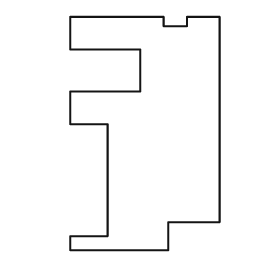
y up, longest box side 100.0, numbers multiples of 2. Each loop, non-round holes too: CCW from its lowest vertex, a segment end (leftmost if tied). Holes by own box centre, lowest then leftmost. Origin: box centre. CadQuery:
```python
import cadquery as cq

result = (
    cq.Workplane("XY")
    .moveTo(-32.0, -50.0)
    .lineTo(10.0, -50.0)
    .lineTo(10.0, -38.0)
    .lineTo(32.0, -38.0)
    .lineTo(32.0, 50.0)
    .lineTo(18.0, 50.0)
    .lineTo(18.0, 46.0)
    .lineTo(8.0, 46.0)
    .lineTo(8.0, 50.0)
    .lineTo(-32.0, 50.0)
    .lineTo(-32.0, 36.0)
    .lineTo(-2.0, 36.0)
    .lineTo(-2.0, 18.0)
    .lineTo(-32.0, 18.0)
    .lineTo(-32.0, 4.0)
    .lineTo(-16.0, 4.0)
    .lineTo(-16.0, -44.0)
    .lineTo(-32.0, -44.0)
    .close()
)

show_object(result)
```